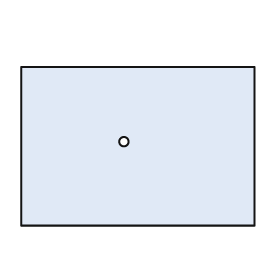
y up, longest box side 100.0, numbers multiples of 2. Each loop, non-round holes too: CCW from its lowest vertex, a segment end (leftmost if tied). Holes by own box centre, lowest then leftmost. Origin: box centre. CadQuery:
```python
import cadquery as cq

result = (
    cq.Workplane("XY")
    .moveTo(-50.0, -34.0)
    .lineTo(50.0, -34.0)
    .lineTo(50.0, 34.0)
    .lineTo(-50.0, 34.0)
    .close()
    .moveTo(-6.0, 2.0)
    .circle(2.0)
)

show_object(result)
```